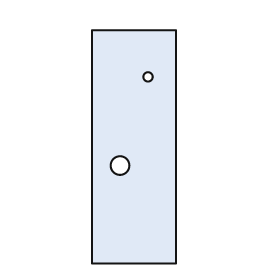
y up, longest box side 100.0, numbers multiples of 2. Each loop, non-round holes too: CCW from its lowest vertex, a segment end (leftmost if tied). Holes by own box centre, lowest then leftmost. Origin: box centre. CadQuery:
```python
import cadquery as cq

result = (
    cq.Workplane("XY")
    .moveTo(-18.0, -50.0)
    .lineTo(18.0, -50.0)
    .lineTo(18.0, 50.0)
    .lineTo(-18.0, 50.0)
    .close()
    .moveTo(-6.0, -8.0)
    .circle(4.0)
    .moveTo(6.0, 30.0)
    .circle(2.0)
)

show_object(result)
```